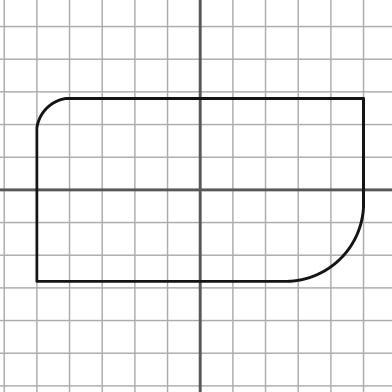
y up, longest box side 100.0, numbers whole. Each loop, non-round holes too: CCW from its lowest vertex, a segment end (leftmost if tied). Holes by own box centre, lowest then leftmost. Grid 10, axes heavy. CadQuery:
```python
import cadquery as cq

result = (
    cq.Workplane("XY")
    .moveTo(-50.0, -28.0)
    .lineTo(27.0, -28.0)
    .threePointArc((43.0, -21.0), (50.0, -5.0))
    .lineTo(50.0, 28.0)
    .lineTo(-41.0, 28.0)
    .threePointArc((-47.0, 25.0), (-50.0, 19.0))
    .close()
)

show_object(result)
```